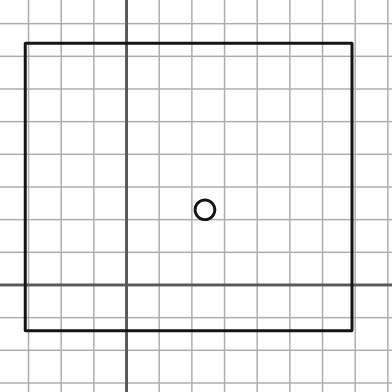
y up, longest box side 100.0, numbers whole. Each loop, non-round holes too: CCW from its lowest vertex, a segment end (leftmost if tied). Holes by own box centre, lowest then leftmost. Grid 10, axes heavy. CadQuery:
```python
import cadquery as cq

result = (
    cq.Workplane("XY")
    .moveTo(-31.0, -14.0)
    .lineTo(69.0, -14.0)
    .lineTo(69.0, 74.0)
    .lineTo(-31.0, 74.0)
    .close()
    .moveTo(24.0, 23.0)
    .circle(3.0)
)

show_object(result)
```